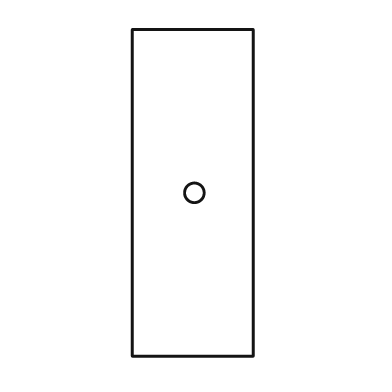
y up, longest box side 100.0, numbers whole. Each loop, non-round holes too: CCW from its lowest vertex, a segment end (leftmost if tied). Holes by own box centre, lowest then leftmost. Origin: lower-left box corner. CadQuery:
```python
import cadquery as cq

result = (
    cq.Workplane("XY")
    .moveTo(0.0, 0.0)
    .lineTo(37.0, 0.0)
    .lineTo(37.0, 100.0)
    .lineTo(0.0, 100.0)
    .close()
    .moveTo(19.0, 50.0)
    .circle(3.0)
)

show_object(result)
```